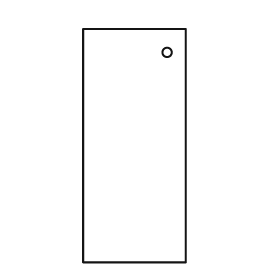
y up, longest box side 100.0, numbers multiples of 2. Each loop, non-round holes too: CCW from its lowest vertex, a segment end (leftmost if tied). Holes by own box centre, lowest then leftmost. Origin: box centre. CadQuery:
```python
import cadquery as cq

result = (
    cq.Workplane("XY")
    .moveTo(-22.0, -50.0)
    .lineTo(22.0, -50.0)
    .lineTo(22.0, 50.0)
    .lineTo(-22.0, 50.0)
    .close()
    .moveTo(14.0, 40.0)
    .circle(2.0)
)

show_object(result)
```